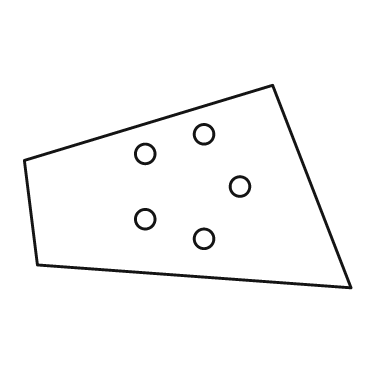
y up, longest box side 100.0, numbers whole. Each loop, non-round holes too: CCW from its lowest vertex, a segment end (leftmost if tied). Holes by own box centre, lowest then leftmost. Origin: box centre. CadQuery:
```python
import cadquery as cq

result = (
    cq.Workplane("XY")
    .moveTo(50.0, -31.0)
    .lineTo(26.0, 31.0)
    .lineTo(-50.0, 8.0)
    .lineTo(-46.0, -24.0)
    .close()
    .moveTo(5.0, -16.0)
    .circle(3.0)
    .moveTo(-13.0, -10.0)
    .circle(3.0)
    .moveTo(16.0, 0.0)
    .circle(3.0)
    .moveTo(-13.0, 10.0)
    .circle(3.0)
    .moveTo(5.0, 16.0)
    .circle(3.0)
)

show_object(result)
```